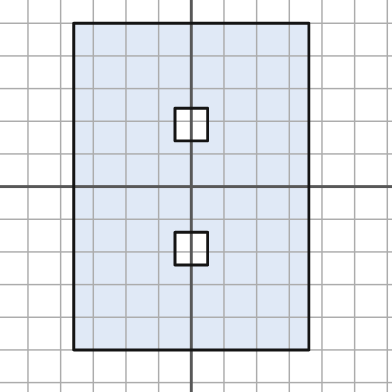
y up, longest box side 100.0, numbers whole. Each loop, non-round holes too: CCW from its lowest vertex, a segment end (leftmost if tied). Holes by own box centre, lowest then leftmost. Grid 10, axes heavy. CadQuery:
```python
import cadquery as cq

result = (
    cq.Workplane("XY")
    .moveTo(-36.0, -50.0)
    .lineTo(36.0, -50.0)
    .lineTo(36.0, 50.0)
    .lineTo(-36.0, 50.0)
    .close()
    .moveTo(-5.0, -24.0)
    .lineTo(5.0, -24.0)
    .lineTo(5.0, -14.0)
    .lineTo(-5.0, -14.0)
    .close()
    .moveTo(-5.0, 14.0)
    .lineTo(5.0, 14.0)
    .lineTo(5.0, 24.0)
    .lineTo(-5.0, 24.0)
    .close()
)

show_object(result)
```